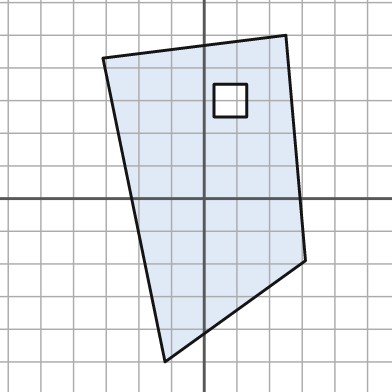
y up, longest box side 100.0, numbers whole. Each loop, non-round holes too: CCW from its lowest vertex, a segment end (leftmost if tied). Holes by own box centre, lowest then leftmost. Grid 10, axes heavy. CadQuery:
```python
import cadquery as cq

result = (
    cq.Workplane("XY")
    .moveTo(-12.0, -50.0)
    .lineTo(31.0, -19.0)
    .lineTo(25.0, 50.0)
    .lineTo(-31.0, 43.0)
    .close()
    .moveTo(3.0, 25.0)
    .lineTo(13.0, 25.0)
    .lineTo(13.0, 35.0)
    .lineTo(3.0, 35.0)
    .close()
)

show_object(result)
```